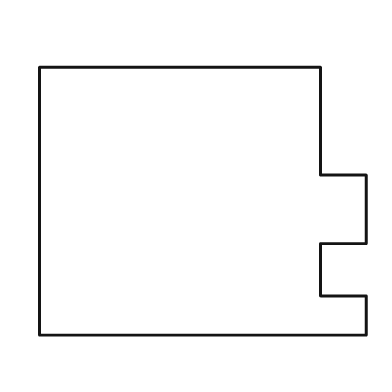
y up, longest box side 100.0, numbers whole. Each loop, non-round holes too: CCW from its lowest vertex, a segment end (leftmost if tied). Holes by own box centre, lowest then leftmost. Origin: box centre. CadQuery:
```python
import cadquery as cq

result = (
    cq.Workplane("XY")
    .moveTo(-50.0, -41.0)
    .lineTo(50.0, -41.0)
    .lineTo(50.0, -29.0)
    .lineTo(36.0, -29.0)
    .lineTo(36.0, -13.0)
    .lineTo(50.0, -13.0)
    .lineTo(50.0, 8.0)
    .lineTo(36.0, 8.0)
    .lineTo(36.0, 41.0)
    .lineTo(-50.0, 41.0)
    .close()
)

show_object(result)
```